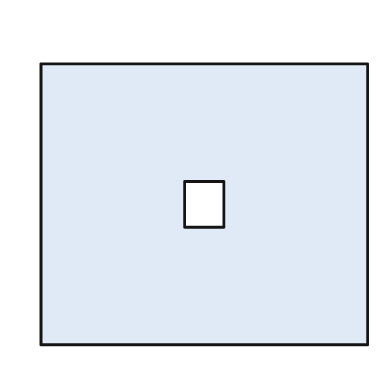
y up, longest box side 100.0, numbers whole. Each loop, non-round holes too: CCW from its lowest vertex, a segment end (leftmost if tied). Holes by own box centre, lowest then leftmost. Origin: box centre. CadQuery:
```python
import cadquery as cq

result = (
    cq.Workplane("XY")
    .moveTo(-50.0, -43.0)
    .lineTo(50.0, -43.0)
    .lineTo(50.0, 43.0)
    .lineTo(-50.0, 43.0)
    .close()
    .moveTo(-6.0, -7.0)
    .lineTo(6.0, -7.0)
    .lineTo(6.0, 7.0)
    .lineTo(-6.0, 7.0)
    .close()
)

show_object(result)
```